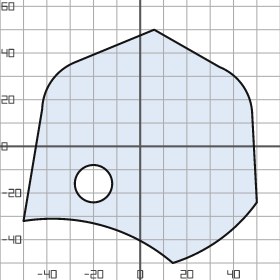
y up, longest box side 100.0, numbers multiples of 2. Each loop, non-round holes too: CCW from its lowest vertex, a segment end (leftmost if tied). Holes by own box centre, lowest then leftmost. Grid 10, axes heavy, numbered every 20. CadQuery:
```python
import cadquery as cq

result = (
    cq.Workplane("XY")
    .moveTo(14.0, -50.0)
    .threePointArc((34.0, -40.0), (50.0, -24.0))
    .lineTo(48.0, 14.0)
    .threePointArc((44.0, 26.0), (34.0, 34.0))
    .lineTo(6.0, 50.0)
    .lineTo(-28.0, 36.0)
    .threePointArc((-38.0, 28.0), (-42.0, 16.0))
    .lineTo(-50.0, -32.0)
    .threePointArc((-16.0, -34.0), (14.0, -50.0))
    .close()
    .moveTo(-20.0, -16.0)
    .circle(8.0)
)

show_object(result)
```